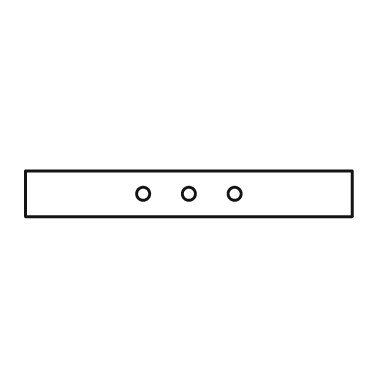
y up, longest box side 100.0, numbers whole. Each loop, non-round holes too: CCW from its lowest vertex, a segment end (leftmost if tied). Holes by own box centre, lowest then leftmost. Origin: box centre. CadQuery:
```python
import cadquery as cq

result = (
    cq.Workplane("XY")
    .moveTo(-50.0, -7.0)
    .lineTo(50.0, -7.0)
    .lineTo(50.0, 7.0)
    .lineTo(-50.0, 7.0)
    .close()
    .moveTo(-14.0, 0.0)
    .circle(2.0)
    .moveTo(0.0, 0.0)
    .circle(2.0)
    .moveTo(14.0, 0.0)
    .circle(2.0)
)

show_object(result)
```